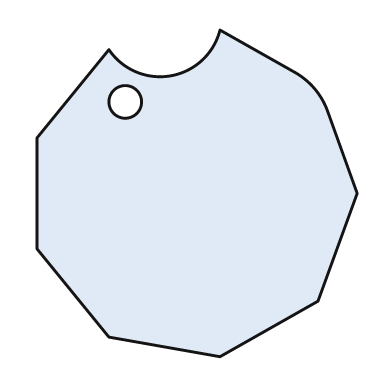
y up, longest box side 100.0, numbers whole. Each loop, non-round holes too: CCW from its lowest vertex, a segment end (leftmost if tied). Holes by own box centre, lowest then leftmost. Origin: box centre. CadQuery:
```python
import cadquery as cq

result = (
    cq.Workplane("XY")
    .moveTo(7.0, -50.0)
    .lineTo(37.0, -33.0)
    .lineTo(49.0, 0.0)
    .lineTo(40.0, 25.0)
    .threePointArc((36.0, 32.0), (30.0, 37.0))
    .lineTo(7.0, 50.0)
    .threePointArc((-8.0, 36.0), (-27.0, 44.0))
    .lineTo(-49.0, 17.0)
    .lineTo(-49.0, -17.0)
    .lineTo(-27.0, -44.0)
    .close()
    .moveTo(-22.0, 28.0)
    .circle(5.0)
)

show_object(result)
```